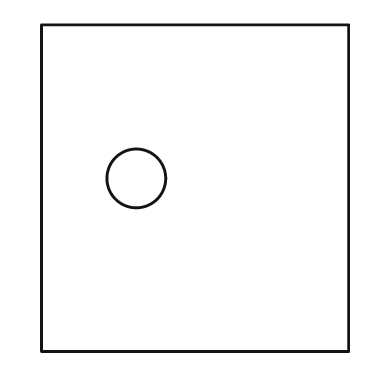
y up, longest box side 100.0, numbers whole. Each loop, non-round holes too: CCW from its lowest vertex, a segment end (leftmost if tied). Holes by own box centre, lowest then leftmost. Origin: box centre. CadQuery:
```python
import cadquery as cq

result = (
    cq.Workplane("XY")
    .moveTo(-47.0, -50.0)
    .lineTo(47.0, -50.0)
    .lineTo(47.0, 50.0)
    .lineTo(-47.0, 50.0)
    .close()
    .moveTo(-18.0, 3.0)
    .circle(9.0)
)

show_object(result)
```